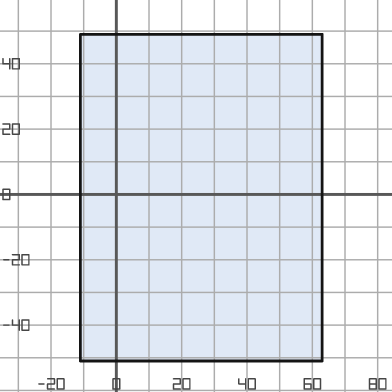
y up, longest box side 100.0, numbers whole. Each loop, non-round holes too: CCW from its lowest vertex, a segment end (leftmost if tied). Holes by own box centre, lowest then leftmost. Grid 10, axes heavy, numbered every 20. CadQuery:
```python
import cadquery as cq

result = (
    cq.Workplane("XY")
    .moveTo(-11.0, -51.0)
    .lineTo(63.0, -51.0)
    .lineTo(63.0, 49.0)
    .lineTo(-11.0, 49.0)
    .close()
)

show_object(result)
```